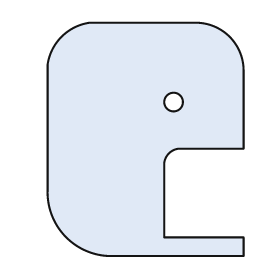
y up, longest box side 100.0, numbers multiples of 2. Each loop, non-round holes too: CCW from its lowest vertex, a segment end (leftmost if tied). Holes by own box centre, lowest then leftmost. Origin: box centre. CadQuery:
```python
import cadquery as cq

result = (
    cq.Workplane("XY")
    .moveTo(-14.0, -50.0)
    .lineTo(42.0, -50.0)
    .lineTo(42.0, -42.0)
    .lineTo(8.0, -42.0)
    .lineTo(8.0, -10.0)
    .threePointArc((10.0, -6.0), (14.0, -4.0))
    .lineTo(42.0, -4.0)
    .lineTo(42.0, 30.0)
    .threePointArc((36.0, 44.0), (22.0, 50.0))
    .lineTo(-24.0, 50.0)
    .threePointArc((-36.0, 44.0), (-42.0, 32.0))
    .lineTo(-42.0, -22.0)
    .threePointArc((-34.0, -42.0), (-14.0, -50.0))
    .close()
    .moveTo(12.0, 16.0)
    .circle(4.0)
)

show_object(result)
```